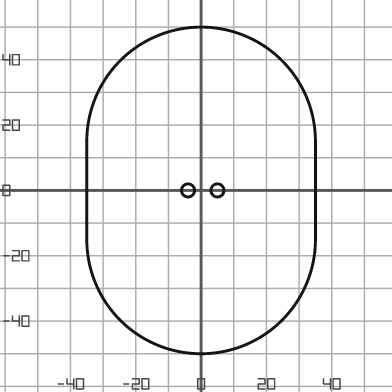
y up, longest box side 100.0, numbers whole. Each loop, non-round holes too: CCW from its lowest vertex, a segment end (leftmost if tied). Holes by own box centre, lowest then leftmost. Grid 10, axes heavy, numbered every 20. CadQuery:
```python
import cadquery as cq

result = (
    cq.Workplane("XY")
    .moveTo(-35.0, -15.0)
    .threePointArc((0.0, -50.0), (35.0, -15.0))
    .lineTo(35.0, 15.0)
    .threePointArc((0.0, 50.0), (-35.0, 15.0))
    .close()
    .moveTo(-4.0, 0.0)
    .circle(2.0)
    .moveTo(5.0, 0.0)
    .circle(2.0)
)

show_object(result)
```